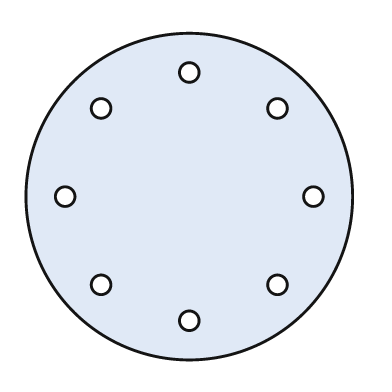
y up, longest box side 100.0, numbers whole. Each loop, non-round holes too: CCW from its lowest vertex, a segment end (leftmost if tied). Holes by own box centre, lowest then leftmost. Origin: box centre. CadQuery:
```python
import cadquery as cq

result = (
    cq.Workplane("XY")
    .moveTo(0.0, 0.0)
    .circle(50.0)
    .moveTo(0.0, -38.0)
    .circle(3.0)
    .moveTo(-27.0, -27.0)
    .circle(3.0)
    .moveTo(27.0, -27.0)
    .circle(3.0)
    .moveTo(-38.0, 0.0)
    .circle(3.0)
    .moveTo(38.0, 0.0)
    .circle(3.0)
    .moveTo(-27.0, 27.0)
    .circle(3.0)
    .moveTo(27.0, 27.0)
    .circle(3.0)
    .moveTo(0.0, 38.0)
    .circle(3.0)
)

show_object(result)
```